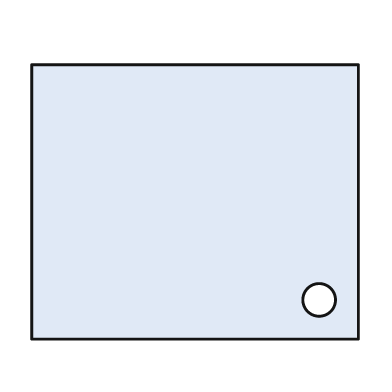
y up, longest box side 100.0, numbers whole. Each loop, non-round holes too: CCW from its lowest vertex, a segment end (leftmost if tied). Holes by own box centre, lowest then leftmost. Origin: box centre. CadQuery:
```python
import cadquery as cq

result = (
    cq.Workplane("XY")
    .moveTo(-50.0, -42.0)
    .lineTo(50.0, -42.0)
    .lineTo(50.0, 42.0)
    .lineTo(-50.0, 42.0)
    .close()
    .moveTo(38.0, -30.0)
    .circle(5.0)
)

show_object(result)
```